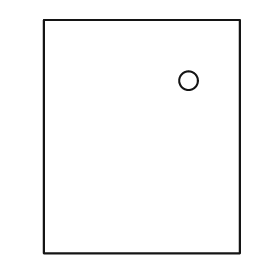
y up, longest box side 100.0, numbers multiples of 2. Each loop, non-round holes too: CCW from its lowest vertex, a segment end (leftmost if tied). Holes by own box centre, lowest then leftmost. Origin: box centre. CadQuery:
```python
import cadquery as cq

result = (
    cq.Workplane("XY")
    .moveTo(-42.0, -50.0)
    .lineTo(42.0, -50.0)
    .lineTo(42.0, 50.0)
    .lineTo(-42.0, 50.0)
    .close()
    .moveTo(20.0, 24.0)
    .circle(4.0)
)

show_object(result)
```